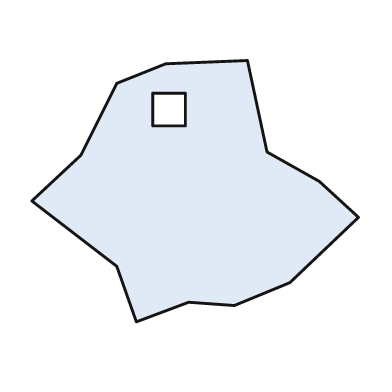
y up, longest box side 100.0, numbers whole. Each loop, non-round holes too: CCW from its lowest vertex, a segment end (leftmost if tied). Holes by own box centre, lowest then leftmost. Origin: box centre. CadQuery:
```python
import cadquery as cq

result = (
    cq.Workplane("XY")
    .moveTo(-18.0, -40.0)
    .lineTo(-2.0, -34.0)
    .lineTo(12.0, -35.0)
    .lineTo(29.0, -28.0)
    .lineTo(50.0, -8.0)
    .lineTo(38.0, 3.0)
    .lineTo(22.0, 12.0)
    .lineTo(16.0, 40.0)
    .lineTo(-9.0, 39.0)
    .lineTo(-24.0, 33.0)
    .lineTo(-35.0, 11.0)
    .lineTo(-50.0, -3.0)
    .lineTo(-24.0, -23.0)
    .close()
    .moveTo(-13.0, 20.0)
    .lineTo(-3.0, 20.0)
    .lineTo(-3.0, 30.0)
    .lineTo(-13.0, 30.0)
    .close()
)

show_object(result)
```